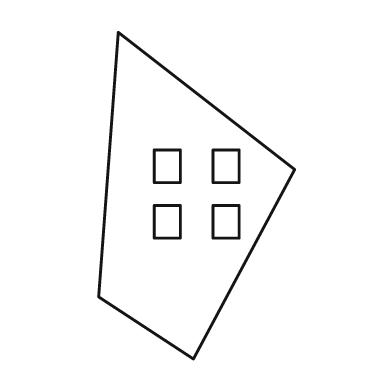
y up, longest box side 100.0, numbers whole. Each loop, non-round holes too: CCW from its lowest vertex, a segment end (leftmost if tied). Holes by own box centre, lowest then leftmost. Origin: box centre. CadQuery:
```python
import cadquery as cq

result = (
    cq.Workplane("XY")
    .moveTo(-1.0, -50.0)
    .lineTo(30.0, 8.0)
    .lineTo(-24.0, 50.0)
    .lineTo(-30.0, -31.0)
    .close()
    .moveTo(-13.0, -13.0)
    .lineTo(-5.0, -13.0)
    .lineTo(-5.0, -3.0)
    .lineTo(-13.0, -3.0)
    .close()
    .moveTo(5.0, -13.0)
    .lineTo(13.0, -13.0)
    .lineTo(13.0, -3.0)
    .lineTo(5.0, -3.0)
    .close()
    .moveTo(-13.0, 4.0)
    .lineTo(-5.0, 4.0)
    .lineTo(-5.0, 14.0)
    .lineTo(-13.0, 14.0)
    .close()
    .moveTo(5.0, 4.0)
    .lineTo(13.0, 4.0)
    .lineTo(13.0, 14.0)
    .lineTo(5.0, 14.0)
    .close()
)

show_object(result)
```